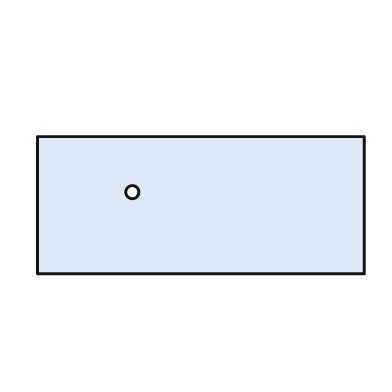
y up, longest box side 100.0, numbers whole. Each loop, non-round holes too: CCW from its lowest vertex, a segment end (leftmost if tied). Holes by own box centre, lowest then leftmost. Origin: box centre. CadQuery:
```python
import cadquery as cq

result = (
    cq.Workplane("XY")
    .moveTo(-50.0, -21.0)
    .lineTo(50.0, -21.0)
    .lineTo(50.0, 21.0)
    .lineTo(-50.0, 21.0)
    .close()
    .moveTo(-21.0, 4.0)
    .circle(2.0)
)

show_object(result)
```